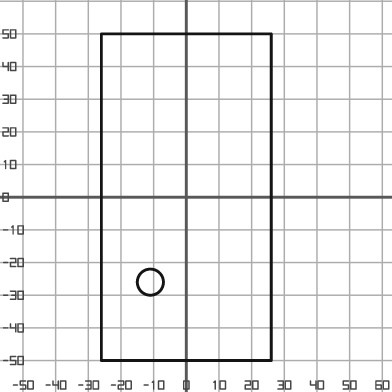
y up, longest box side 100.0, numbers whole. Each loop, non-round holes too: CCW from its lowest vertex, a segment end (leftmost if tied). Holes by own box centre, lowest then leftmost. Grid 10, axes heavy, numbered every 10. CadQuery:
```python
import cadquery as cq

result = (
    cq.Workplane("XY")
    .moveTo(-26.0, -50.0)
    .lineTo(26.0, -50.0)
    .lineTo(26.0, 50.0)
    .lineTo(-26.0, 50.0)
    .close()
    .moveTo(-11.0, -26.0)
    .circle(4.0)
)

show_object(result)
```